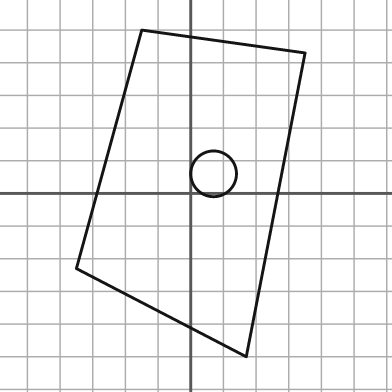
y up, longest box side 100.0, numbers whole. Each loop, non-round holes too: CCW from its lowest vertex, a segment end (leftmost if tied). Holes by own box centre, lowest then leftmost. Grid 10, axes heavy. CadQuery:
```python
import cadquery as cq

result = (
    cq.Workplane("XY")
    .moveTo(17.0, -50.0)
    .lineTo(35.0, 43.0)
    .lineTo(-15.0, 50.0)
    .lineTo(-35.0, -23.0)
    .close()
    .moveTo(7.0, 6.0)
    .circle(7.0)
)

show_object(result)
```